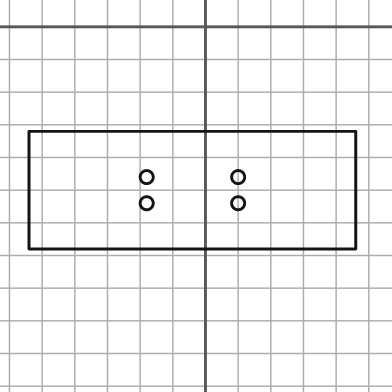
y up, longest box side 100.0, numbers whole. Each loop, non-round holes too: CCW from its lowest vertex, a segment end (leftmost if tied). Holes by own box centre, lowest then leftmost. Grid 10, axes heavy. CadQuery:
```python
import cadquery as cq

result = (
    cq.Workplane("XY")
    .moveTo(-54.0, -68.0)
    .lineTo(46.0, -68.0)
    .lineTo(46.0, -32.0)
    .lineTo(-54.0, -32.0)
    .close()
    .moveTo(-18.0, -54.0)
    .circle(2.0)
    .moveTo(10.0, -54.0)
    .circle(2.0)
    .moveTo(-18.0, -46.0)
    .circle(2.0)
    .moveTo(10.0, -46.0)
    .circle(2.0)
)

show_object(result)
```